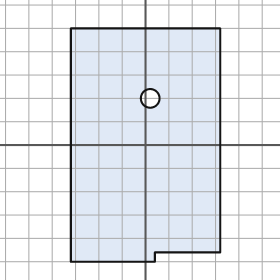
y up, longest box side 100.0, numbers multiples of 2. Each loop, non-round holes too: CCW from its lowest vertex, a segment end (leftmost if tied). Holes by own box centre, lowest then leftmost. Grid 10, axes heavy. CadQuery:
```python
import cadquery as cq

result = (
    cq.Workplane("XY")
    .moveTo(-32.0, -50.0)
    .lineTo(4.0, -50.0)
    .lineTo(4.0, -46.0)
    .lineTo(32.0, -46.0)
    .lineTo(32.0, 50.0)
    .lineTo(-32.0, 50.0)
    .close()
    .moveTo(2.0, 20.0)
    .circle(4.0)
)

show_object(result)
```